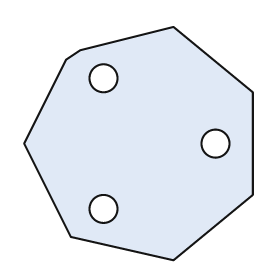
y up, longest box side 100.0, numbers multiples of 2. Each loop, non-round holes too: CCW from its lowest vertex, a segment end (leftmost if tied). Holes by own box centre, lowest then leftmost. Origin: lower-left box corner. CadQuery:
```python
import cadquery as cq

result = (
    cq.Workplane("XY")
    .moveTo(64.0, 0.0)
    .lineTo(98.0, 28.0)
    .lineTo(98.0, 72.0)
    .lineTo(64.0, 100.0)
    .lineTo(24.0, 90.0)
    .lineTo(18.0, 86.0)
    .lineTo(0.0, 50.0)
    .lineTo(20.0, 10.0)
    .close()
    .moveTo(34.0, 22.0)
    .circle(6.0)
    .moveTo(82.0, 50.0)
    .circle(6.0)
    .moveTo(34.0, 78.0)
    .circle(6.0)
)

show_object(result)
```